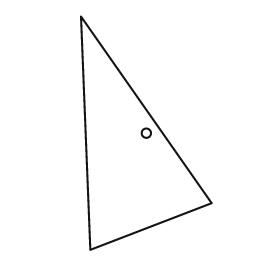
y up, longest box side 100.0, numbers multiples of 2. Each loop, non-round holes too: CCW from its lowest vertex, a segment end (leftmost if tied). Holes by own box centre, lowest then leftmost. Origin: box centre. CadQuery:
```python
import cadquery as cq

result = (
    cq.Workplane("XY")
    .moveTo(-24.0, -50.0)
    .lineTo(28.0, -30.0)
    .lineTo(-28.0, 50.0)
    .close()
    .moveTo(0.0, 0.0)
    .circle(2.0)
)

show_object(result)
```